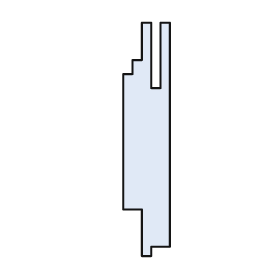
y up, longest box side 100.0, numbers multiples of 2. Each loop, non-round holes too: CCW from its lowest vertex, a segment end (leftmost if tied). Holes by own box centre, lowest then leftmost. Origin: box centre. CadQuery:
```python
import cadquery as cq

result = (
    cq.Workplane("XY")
    .moveTo(-2.0, -50.0)
    .lineTo(2.0, -50.0)
    .lineTo(2.0, -46.0)
    .lineTo(10.0, -46.0)
    .lineTo(10.0, 50.0)
    .lineTo(6.0, 50.0)
    .lineTo(6.0, 22.0)
    .lineTo(2.0, 22.0)
    .lineTo(2.0, 50.0)
    .lineTo(-2.0, 50.0)
    .lineTo(-2.0, 34.0)
    .lineTo(-6.0, 34.0)
    .lineTo(-6.0, 28.0)
    .lineTo(-10.0, 28.0)
    .lineTo(-10.0, -30.0)
    .lineTo(-2.0, -30.0)
    .close()
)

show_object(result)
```